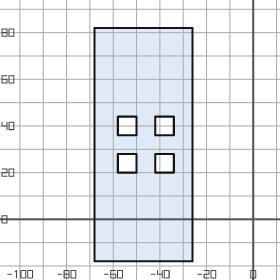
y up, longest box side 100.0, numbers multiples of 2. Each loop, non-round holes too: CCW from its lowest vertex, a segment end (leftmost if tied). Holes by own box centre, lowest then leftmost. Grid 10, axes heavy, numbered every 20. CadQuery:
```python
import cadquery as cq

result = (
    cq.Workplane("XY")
    .moveTo(-68.0, -18.0)
    .lineTo(-26.0, -18.0)
    .lineTo(-26.0, 82.0)
    .lineTo(-68.0, 82.0)
    .close()
    .moveTo(-58.0, 20.0)
    .lineTo(-50.0, 20.0)
    .lineTo(-50.0, 28.0)
    .lineTo(-58.0, 28.0)
    .close()
    .moveTo(-42.0, 20.0)
    .lineTo(-34.0, 20.0)
    .lineTo(-34.0, 28.0)
    .lineTo(-42.0, 28.0)
    .close()
    .moveTo(-58.0, 36.0)
    .lineTo(-50.0, 36.0)
    .lineTo(-50.0, 44.0)
    .lineTo(-58.0, 44.0)
    .close()
    .moveTo(-42.0, 36.0)
    .lineTo(-34.0, 36.0)
    .lineTo(-34.0, 44.0)
    .lineTo(-42.0, 44.0)
    .close()
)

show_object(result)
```